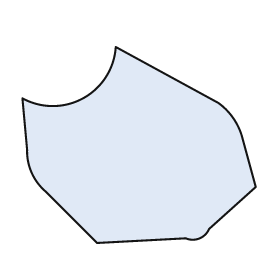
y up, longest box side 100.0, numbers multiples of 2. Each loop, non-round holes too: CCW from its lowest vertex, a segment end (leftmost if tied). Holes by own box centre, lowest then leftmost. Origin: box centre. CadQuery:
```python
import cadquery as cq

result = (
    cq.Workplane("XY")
    .moveTo(-18.0, -42.0)
    .lineTo(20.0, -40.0)
    .threePointArc((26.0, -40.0), (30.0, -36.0))
    .lineTo(50.0, -18.0)
    .lineTo(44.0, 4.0)
    .threePointArc((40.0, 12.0), (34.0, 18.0))
    .lineTo(-10.0, 42.0)
    .threePointArc((-24.0, 20.0), (-50.0, 20.0))
    .lineTo(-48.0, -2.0)
    .threePointArc((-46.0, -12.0), (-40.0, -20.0))
    .close()
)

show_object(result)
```